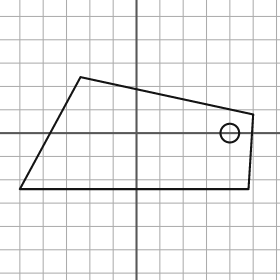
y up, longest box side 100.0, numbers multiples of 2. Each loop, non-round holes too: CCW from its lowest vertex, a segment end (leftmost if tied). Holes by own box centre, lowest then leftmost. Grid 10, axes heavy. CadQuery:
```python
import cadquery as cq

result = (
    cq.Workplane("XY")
    .moveTo(-50.0, -24.0)
    .lineTo(48.0, -24.0)
    .lineTo(50.0, 8.0)
    .lineTo(-24.0, 24.0)
    .close()
    .moveTo(40.0, 0.0)
    .circle(4.0)
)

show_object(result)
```